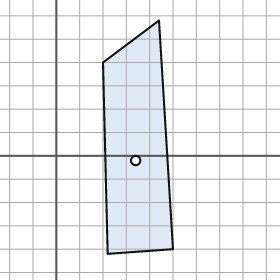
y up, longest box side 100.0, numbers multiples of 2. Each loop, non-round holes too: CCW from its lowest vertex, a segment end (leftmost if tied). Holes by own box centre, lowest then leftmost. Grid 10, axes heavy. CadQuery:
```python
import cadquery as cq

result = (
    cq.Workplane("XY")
    .moveTo(22.0, -42.0)
    .lineTo(50.0, -40.0)
    .lineTo(44.0, 58.0)
    .lineTo(20.0, 40.0)
    .close()
    .moveTo(34.0, -2.0)
    .circle(2.0)
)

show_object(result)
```